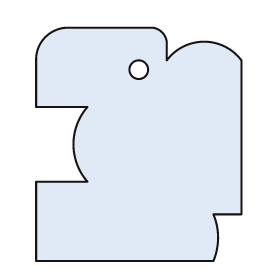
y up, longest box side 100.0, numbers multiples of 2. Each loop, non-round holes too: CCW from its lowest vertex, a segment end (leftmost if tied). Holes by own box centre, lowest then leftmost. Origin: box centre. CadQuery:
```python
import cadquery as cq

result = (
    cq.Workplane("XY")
    .moveTo(-44.0, -50.0)
    .lineTo(32.0, -50.0)
    .threePointArc((34.0, -40.0), (32.0, -30.0))
    .lineTo(44.0, -30.0)
    .lineTo(44.0, 36.0)
    .threePointArc((28.0, 44.0), (12.0, 36.0))
    .lineTo(12.0, 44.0)
    .threePointArc((10.0, 48.0), (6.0, 50.0))
    .lineTo(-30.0, 50.0)
    .threePointArc((-40.0, 46.0), (-44.0, 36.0))
    .lineTo(-44.0, 16.0)
    .lineTo(-22.0, 16.0)
    .threePointArc((-28.0, 0.0), (-22.0, -16.0))
    .lineTo(-44.0, -16.0)
    .close()
    .moveTo(0.0, 32.0)
    .circle(4.0)
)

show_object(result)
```